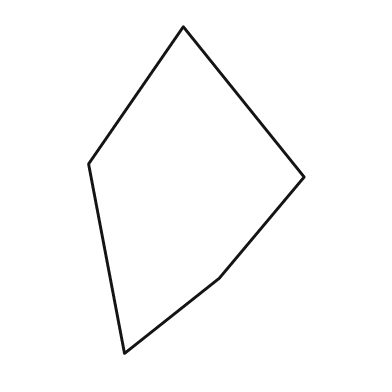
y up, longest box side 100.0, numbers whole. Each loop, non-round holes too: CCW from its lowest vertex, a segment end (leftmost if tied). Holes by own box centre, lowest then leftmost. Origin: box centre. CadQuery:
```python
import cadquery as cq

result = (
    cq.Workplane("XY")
    .moveTo(-22.0, -50.0)
    .lineTo(7.0, -27.0)
    .lineTo(33.0, 4.0)
    .lineTo(-4.0, 50.0)
    .lineTo(-33.0, 8.0)
    .close()
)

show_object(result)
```